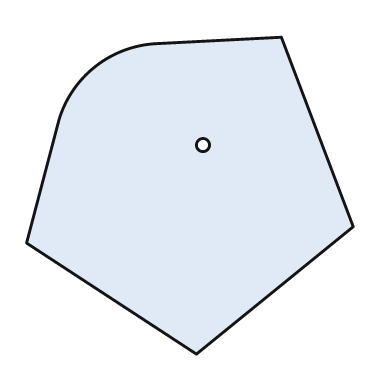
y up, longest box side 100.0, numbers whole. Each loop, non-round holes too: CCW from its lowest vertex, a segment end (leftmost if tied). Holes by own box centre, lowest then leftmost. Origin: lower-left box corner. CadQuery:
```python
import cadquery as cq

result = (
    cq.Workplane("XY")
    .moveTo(52.0, 0.0)
    .lineTo(100.0, 39.0)
    .lineTo(78.0, 97.0)
    .lineTo(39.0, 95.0)
    .threePointArc((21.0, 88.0), (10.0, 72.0))
    .lineTo(0.0, 34.0)
    .close()
    .moveTo(54.0, 64.0)
    .circle(2.0)
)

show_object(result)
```